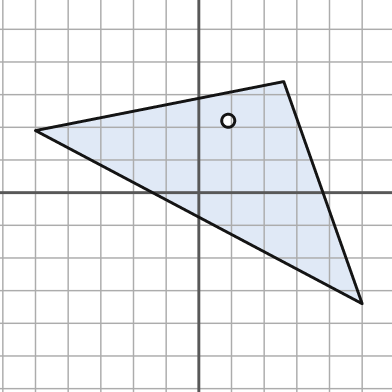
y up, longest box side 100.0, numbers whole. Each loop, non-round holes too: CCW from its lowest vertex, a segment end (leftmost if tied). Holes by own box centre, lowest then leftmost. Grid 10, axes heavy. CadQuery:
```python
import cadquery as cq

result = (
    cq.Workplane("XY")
    .moveTo(50.0, -34.0)
    .lineTo(26.0, 34.0)
    .lineTo(-50.0, 19.0)
    .close()
    .moveTo(9.0, 22.0)
    .circle(2.0)
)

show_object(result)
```